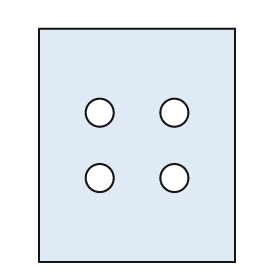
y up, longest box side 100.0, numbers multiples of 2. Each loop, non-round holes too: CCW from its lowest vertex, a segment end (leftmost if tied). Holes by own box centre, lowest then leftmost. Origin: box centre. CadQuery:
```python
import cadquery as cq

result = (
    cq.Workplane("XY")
    .moveTo(-42.0, -50.0)
    .lineTo(42.0, -50.0)
    .lineTo(42.0, 50.0)
    .lineTo(-42.0, 50.0)
    .close()
    .moveTo(-16.0, -14.0)
    .circle(6.0)
    .moveTo(16.0, -14.0)
    .circle(6.0)
    .moveTo(-16.0, 14.0)
    .circle(6.0)
    .moveTo(16.0, 14.0)
    .circle(6.0)
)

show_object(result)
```